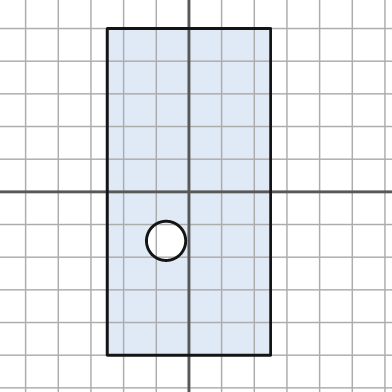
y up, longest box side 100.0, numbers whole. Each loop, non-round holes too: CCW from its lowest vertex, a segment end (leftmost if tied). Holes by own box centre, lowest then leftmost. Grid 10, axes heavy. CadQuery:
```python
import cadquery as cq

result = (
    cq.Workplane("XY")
    .moveTo(-25.0, -50.0)
    .lineTo(25.0, -50.0)
    .lineTo(25.0, 50.0)
    .lineTo(-25.0, 50.0)
    .close()
    .moveTo(-7.0, -15.0)
    .circle(6.0)
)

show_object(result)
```